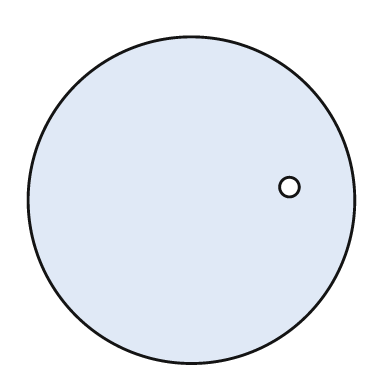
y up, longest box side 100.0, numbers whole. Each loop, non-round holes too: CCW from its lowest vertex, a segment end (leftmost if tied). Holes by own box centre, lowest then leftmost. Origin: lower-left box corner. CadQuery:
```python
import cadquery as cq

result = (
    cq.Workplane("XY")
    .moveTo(50.0, 50.0)
    .circle(50.0)
    .moveTo(80.0, 54.0)
    .circle(3.0)
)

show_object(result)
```